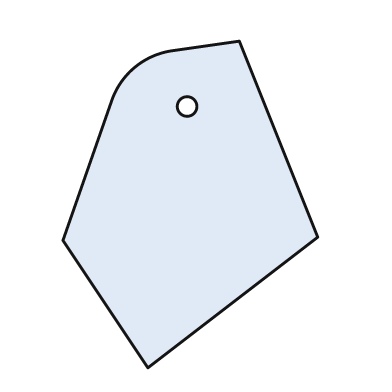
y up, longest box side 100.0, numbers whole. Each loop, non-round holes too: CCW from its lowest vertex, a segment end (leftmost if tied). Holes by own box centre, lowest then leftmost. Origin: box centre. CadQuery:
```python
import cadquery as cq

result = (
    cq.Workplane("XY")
    .moveTo(-13.0, -50.0)
    .lineTo(39.0, -10.0)
    .lineTo(15.0, 50.0)
    .lineTo(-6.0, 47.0)
    .threePointArc((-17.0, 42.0), (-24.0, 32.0))
    .lineTo(-39.0, -11.0)
    .close()
    .moveTo(-1.0, 30.0)
    .circle(3.0)
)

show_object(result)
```